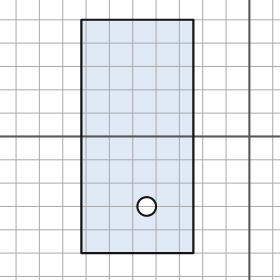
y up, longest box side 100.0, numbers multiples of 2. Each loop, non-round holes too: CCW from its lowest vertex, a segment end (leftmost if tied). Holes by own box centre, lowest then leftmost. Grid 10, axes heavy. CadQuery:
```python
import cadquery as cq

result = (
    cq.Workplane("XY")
    .moveTo(-72.0, -50.0)
    .lineTo(-24.0, -50.0)
    .lineTo(-24.0, 50.0)
    .lineTo(-72.0, 50.0)
    .close()
    .moveTo(-44.0, -30.0)
    .circle(4.0)
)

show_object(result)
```